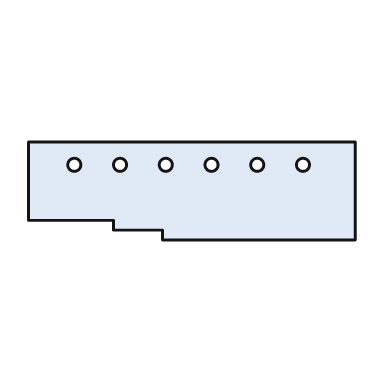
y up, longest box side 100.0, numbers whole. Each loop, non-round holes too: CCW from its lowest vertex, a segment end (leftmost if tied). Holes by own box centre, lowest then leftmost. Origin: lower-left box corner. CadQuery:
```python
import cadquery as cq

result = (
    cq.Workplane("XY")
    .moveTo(41.0, 0.0)
    .lineTo(100.0, 0.0)
    .lineTo(100.0, 30.0)
    .lineTo(0.0, 30.0)
    .lineTo(0.0, 6.0)
    .lineTo(26.0, 6.0)
    .lineTo(26.0, 3.0)
    .lineTo(41.0, 3.0)
    .close()
    .moveTo(14.0, 23.0)
    .circle(2.0)
    .moveTo(28.0, 23.0)
    .circle(2.0)
    .moveTo(42.0, 23.0)
    .circle(2.0)
    .moveTo(56.0, 23.0)
    .circle(2.0)
    .moveTo(70.0, 23.0)
    .circle(2.0)
    .moveTo(84.0, 23.0)
    .circle(2.0)
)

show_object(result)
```